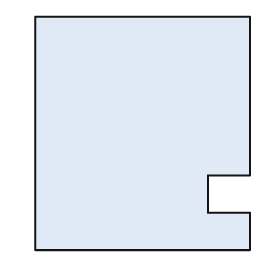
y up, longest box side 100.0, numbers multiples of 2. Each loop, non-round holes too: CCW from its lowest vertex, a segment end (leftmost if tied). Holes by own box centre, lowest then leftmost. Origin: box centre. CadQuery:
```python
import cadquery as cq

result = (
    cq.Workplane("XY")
    .moveTo(-46.0, -50.0)
    .lineTo(46.0, -50.0)
    .lineTo(46.0, -34.0)
    .lineTo(28.0, -34.0)
    .lineTo(28.0, -18.0)
    .lineTo(46.0, -18.0)
    .lineTo(46.0, 50.0)
    .lineTo(-46.0, 50.0)
    .close()
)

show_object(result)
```